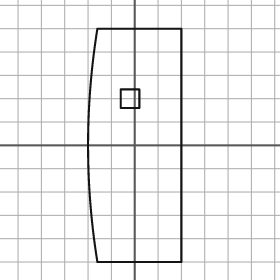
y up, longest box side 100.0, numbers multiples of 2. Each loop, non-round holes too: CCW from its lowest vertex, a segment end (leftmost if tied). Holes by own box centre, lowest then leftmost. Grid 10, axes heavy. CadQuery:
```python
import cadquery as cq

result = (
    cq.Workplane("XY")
    .moveTo(-16.0, -50.0)
    .lineTo(20.0, -50.0)
    .lineTo(20.0, 50.0)
    .lineTo(-16.0, 50.0)
    .threePointArc((-20.0, 0.0), (-16.0, -50.0))
    .close()
    .moveTo(-6.0, 16.0)
    .lineTo(2.0, 16.0)
    .lineTo(2.0, 24.0)
    .lineTo(-6.0, 24.0)
    .close()
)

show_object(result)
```